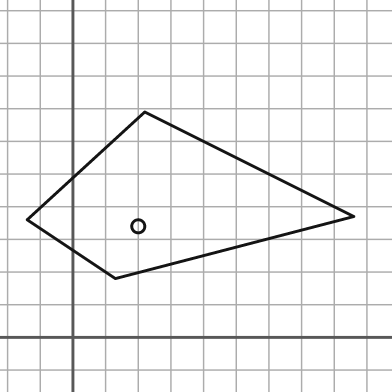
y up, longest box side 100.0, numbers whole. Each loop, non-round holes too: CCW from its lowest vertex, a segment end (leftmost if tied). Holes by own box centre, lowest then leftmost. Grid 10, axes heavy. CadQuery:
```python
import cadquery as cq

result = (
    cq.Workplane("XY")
    .moveTo(13.0, 18.0)
    .lineTo(86.0, 37.0)
    .lineTo(22.0, 69.0)
    .lineTo(-14.0, 36.0)
    .close()
    .moveTo(20.0, 34.0)
    .circle(2.0)
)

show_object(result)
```